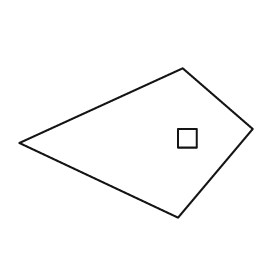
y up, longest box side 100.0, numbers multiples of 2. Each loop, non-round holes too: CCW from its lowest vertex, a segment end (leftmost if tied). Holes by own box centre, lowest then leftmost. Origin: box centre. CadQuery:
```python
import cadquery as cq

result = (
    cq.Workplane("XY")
    .moveTo(18.0, -32.0)
    .lineTo(50.0, 6.0)
    .lineTo(20.0, 32.0)
    .lineTo(-50.0, 0.0)
    .close()
    .moveTo(18.0, -2.0)
    .lineTo(26.0, -2.0)
    .lineTo(26.0, 6.0)
    .lineTo(18.0, 6.0)
    .close()
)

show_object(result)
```